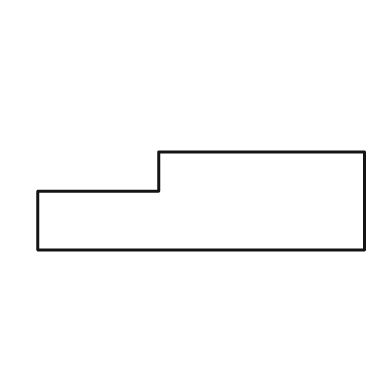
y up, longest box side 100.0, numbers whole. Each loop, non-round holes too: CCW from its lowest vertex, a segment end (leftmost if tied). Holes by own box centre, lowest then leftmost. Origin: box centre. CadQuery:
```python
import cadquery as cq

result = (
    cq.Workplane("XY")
    .moveTo(-50.0, -15.0)
    .lineTo(50.0, -15.0)
    .lineTo(50.0, 15.0)
    .lineTo(-13.0, 15.0)
    .lineTo(-13.0, 3.0)
    .lineTo(-50.0, 3.0)
    .close()
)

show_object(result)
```